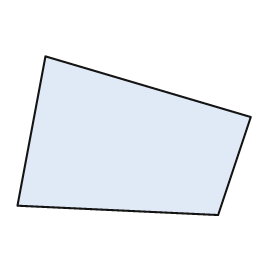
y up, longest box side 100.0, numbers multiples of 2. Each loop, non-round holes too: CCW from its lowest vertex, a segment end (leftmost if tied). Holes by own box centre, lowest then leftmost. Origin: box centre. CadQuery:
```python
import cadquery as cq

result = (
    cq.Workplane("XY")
    .moveTo(36.0, -34.0)
    .lineTo(50.0, 8.0)
    .lineTo(-38.0, 34.0)
    .lineTo(-50.0, -30.0)
    .close()
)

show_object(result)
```